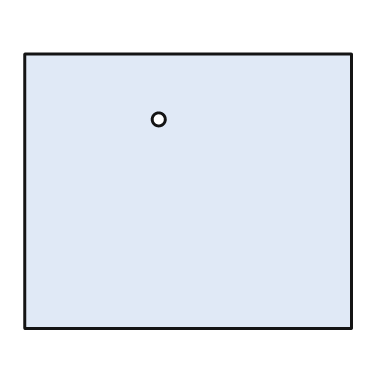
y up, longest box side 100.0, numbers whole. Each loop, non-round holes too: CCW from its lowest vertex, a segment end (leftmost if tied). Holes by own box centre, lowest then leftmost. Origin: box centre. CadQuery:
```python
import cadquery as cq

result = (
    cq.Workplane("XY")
    .moveTo(-50.0, -42.0)
    .lineTo(50.0, -42.0)
    .lineTo(50.0, 42.0)
    .lineTo(-50.0, 42.0)
    .close()
    .moveTo(-9.0, 22.0)
    .circle(2.0)
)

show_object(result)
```